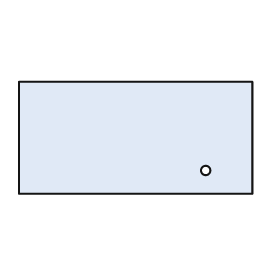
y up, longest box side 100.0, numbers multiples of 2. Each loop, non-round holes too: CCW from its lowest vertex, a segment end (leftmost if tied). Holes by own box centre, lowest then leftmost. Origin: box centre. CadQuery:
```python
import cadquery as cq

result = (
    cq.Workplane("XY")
    .moveTo(-50.0, -24.0)
    .lineTo(50.0, -24.0)
    .lineTo(50.0, 24.0)
    .lineTo(-50.0, 24.0)
    .close()
    .moveTo(30.0, -14.0)
    .circle(2.0)
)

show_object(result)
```